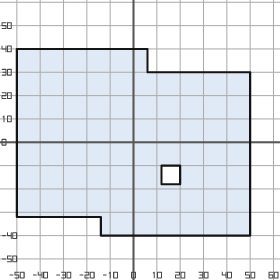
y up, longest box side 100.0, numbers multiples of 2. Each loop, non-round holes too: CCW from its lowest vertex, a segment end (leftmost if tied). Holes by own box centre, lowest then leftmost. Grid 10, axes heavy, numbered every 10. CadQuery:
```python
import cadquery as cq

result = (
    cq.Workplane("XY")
    .moveTo(-14.0, -40.0)
    .lineTo(50.0, -40.0)
    .lineTo(50.0, 30.0)
    .lineTo(6.0, 30.0)
    .lineTo(6.0, 40.0)
    .lineTo(-50.0, 40.0)
    .lineTo(-50.0, -32.0)
    .lineTo(-14.0, -32.0)
    .close()
    .moveTo(12.0, -18.0)
    .lineTo(20.0, -18.0)
    .lineTo(20.0, -10.0)
    .lineTo(12.0, -10.0)
    .close()
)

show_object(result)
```